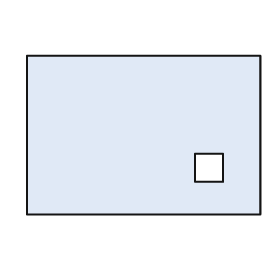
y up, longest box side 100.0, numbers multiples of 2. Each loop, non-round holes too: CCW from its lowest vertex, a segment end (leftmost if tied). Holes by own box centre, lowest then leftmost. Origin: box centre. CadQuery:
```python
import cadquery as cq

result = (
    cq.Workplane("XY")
    .moveTo(-50.0, -34.0)
    .lineTo(50.0, -34.0)
    .lineTo(50.0, 34.0)
    .lineTo(-50.0, 34.0)
    .close()
    .moveTo(22.0, -20.0)
    .lineTo(34.0, -20.0)
    .lineTo(34.0, -8.0)
    .lineTo(22.0, -8.0)
    .close()
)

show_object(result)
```